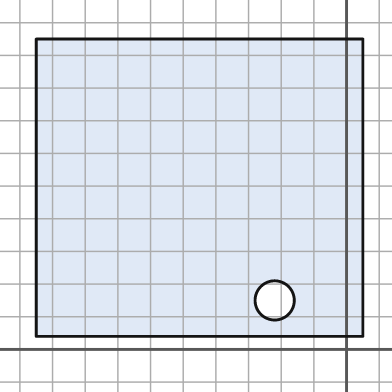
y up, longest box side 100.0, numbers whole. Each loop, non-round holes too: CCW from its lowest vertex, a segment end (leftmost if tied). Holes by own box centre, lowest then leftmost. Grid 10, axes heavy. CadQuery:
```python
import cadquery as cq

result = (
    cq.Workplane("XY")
    .moveTo(-95.0, 4.0)
    .lineTo(5.0, 4.0)
    .lineTo(5.0, 95.0)
    .lineTo(-95.0, 95.0)
    .close()
    .moveTo(-22.0, 15.0)
    .circle(6.0)
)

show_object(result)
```